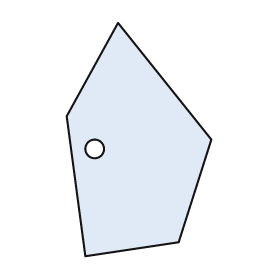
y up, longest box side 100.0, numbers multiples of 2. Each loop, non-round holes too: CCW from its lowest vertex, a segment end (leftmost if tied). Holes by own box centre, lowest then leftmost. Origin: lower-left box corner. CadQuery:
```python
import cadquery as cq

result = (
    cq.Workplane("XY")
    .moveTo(8.0, 0.0)
    .lineTo(48.0, 6.0)
    .lineTo(62.0, 50.0)
    .lineTo(22.0, 100.0)
    .lineTo(0.0, 60.0)
    .close()
    .moveTo(12.0, 46.0)
    .circle(4.0)
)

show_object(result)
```